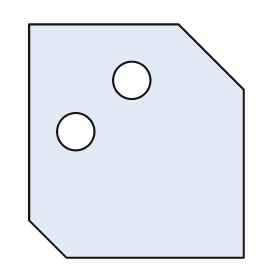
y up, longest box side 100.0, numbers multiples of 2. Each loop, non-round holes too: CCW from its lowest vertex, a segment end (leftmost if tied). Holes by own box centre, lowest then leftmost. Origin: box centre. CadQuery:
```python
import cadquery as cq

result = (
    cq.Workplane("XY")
    .moveTo(-30.0, -50.0)
    .lineTo(46.0, -50.0)
    .lineTo(46.0, 22.0)
    .lineTo(18.0, 50.0)
    .lineTo(-46.0, 50.0)
    .lineTo(-46.0, -34.0)
    .close()
    .moveTo(-26.0, 4.0)
    .circle(8.0)
    .moveTo(-2.0, 26.0)
    .circle(8.0)
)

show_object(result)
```